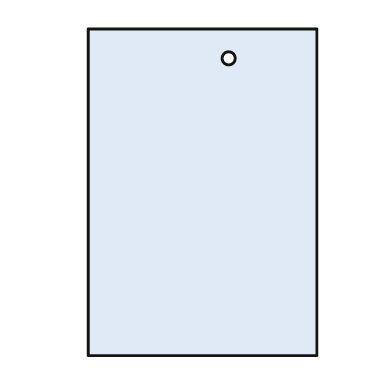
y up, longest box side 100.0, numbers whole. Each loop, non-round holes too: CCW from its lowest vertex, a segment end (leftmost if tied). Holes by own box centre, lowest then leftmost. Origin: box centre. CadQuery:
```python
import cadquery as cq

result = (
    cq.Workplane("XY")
    .moveTo(-35.0, -50.0)
    .lineTo(35.0, -50.0)
    .lineTo(35.0, 50.0)
    .lineTo(-35.0, 50.0)
    .close()
    .moveTo(8.0, 41.0)
    .circle(2.0)
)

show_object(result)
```